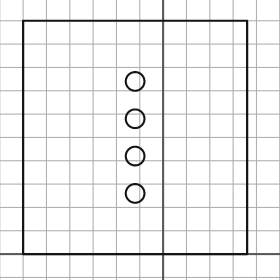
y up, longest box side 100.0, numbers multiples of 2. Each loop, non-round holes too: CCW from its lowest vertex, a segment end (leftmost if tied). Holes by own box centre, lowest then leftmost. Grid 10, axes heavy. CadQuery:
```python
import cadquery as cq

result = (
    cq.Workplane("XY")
    .moveTo(-60.0, 0.0)
    .lineTo(36.0, 0.0)
    .lineTo(36.0, 100.0)
    .lineTo(-60.0, 100.0)
    .close()
    .moveTo(-12.0, 26.0)
    .circle(4.0)
    .moveTo(-12.0, 42.0)
    .circle(4.0)
    .moveTo(-12.0, 58.0)
    .circle(4.0)
    .moveTo(-12.0, 74.0)
    .circle(4.0)
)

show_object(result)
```